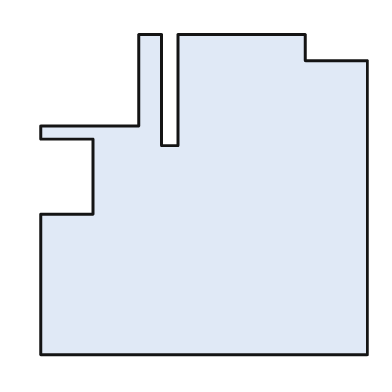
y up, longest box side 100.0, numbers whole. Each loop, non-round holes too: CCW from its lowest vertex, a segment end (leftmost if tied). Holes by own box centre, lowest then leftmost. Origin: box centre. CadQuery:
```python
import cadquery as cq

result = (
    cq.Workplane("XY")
    .moveTo(-50.0, -49.0)
    .lineTo(50.0, -49.0)
    .lineTo(50.0, 41.0)
    .lineTo(31.0, 41.0)
    .lineTo(31.0, 49.0)
    .lineTo(-8.0, 49.0)
    .lineTo(-8.0, 15.0)
    .lineTo(-13.0, 15.0)
    .lineTo(-13.0, 49.0)
    .lineTo(-20.0, 49.0)
    .lineTo(-20.0, 21.0)
    .lineTo(-50.0, 21.0)
    .lineTo(-50.0, 17.0)
    .lineTo(-34.0, 17.0)
    .lineTo(-34.0, -6.0)
    .lineTo(-50.0, -6.0)
    .close()
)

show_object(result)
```